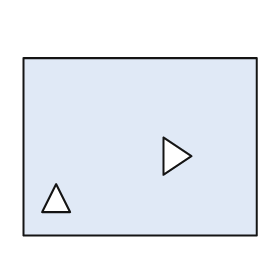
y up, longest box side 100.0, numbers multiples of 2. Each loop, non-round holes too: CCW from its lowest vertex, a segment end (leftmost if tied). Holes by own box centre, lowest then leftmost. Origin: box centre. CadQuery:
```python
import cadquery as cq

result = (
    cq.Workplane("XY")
    .moveTo(-50.0, -38.0)
    .lineTo(50.0, -38.0)
    .lineTo(50.0, 38.0)
    .lineTo(-50.0, 38.0)
    .close()
    .moveTo(-42.0, -28.0)
    .lineTo(-30.0, -28.0)
    .lineTo(-36.0, -16.0)
    .close()
    .moveTo(10.0, -12.0)
    .lineTo(22.0, -4.0)
    .lineTo(10.0, 4.0)
    .close()
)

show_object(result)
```